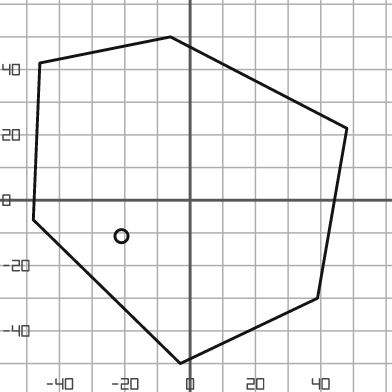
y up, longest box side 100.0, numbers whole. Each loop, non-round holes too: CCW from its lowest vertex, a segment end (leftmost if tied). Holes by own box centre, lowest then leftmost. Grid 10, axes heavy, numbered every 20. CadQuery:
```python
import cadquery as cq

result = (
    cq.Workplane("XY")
    .moveTo(-3.0, -50.0)
    .lineTo(39.0, -30.0)
    .lineTo(48.0, 22.0)
    .lineTo(-6.0, 50.0)
    .lineTo(-46.0, 42.0)
    .lineTo(-48.0, -6.0)
    .close()
    .moveTo(-21.0, -11.0)
    .circle(2.0)
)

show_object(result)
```